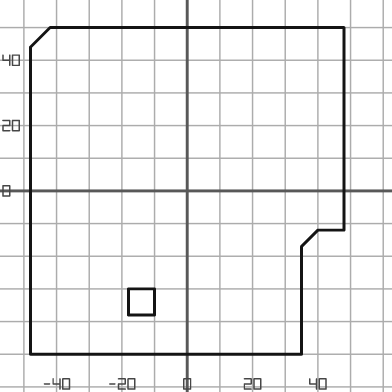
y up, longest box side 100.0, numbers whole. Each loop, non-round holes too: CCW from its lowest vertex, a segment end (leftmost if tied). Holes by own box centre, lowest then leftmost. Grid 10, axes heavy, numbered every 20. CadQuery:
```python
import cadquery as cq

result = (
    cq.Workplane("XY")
    .moveTo(-48.0, -50.0)
    .lineTo(35.0, -50.0)
    .lineTo(35.0, -17.0)
    .lineTo(40.0, -12.0)
    .lineTo(48.0, -12.0)
    .lineTo(48.0, 50.0)
    .lineTo(-42.0, 50.0)
    .lineTo(-48.0, 44.0)
    .close()
    .moveTo(-18.0, -38.0)
    .lineTo(-10.0, -38.0)
    .lineTo(-10.0, -30.0)
    .lineTo(-18.0, -30.0)
    .close()
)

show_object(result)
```